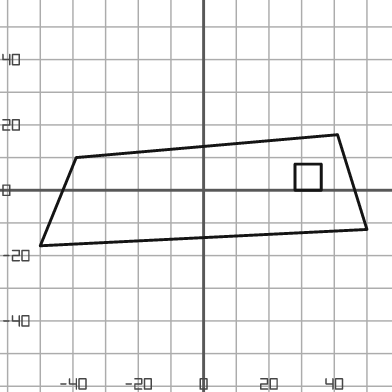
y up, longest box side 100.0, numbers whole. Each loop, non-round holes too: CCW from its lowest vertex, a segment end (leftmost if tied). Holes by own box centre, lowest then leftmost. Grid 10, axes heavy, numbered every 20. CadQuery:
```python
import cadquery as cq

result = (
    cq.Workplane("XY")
    .moveTo(-50.0, -17.0)
    .lineTo(50.0, -12.0)
    .lineTo(41.0, 17.0)
    .lineTo(-39.0, 10.0)
    .close()
    .moveTo(28.0, 0.0)
    .lineTo(36.0, 0.0)
    .lineTo(36.0, 8.0)
    .lineTo(28.0, 8.0)
    .close()
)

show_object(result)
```